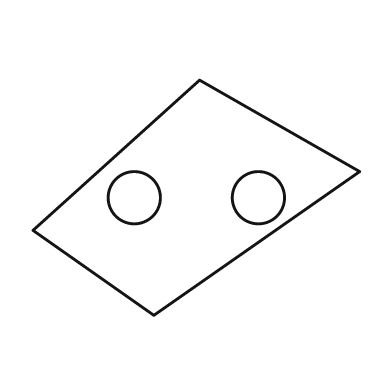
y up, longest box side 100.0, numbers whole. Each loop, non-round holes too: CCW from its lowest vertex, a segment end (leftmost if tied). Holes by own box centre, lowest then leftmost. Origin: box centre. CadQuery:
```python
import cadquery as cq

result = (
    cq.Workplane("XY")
    .moveTo(-13.0, -36.0)
    .lineTo(50.0, 8.0)
    .lineTo(1.0, 36.0)
    .lineTo(-50.0, -10.0)
    .close()
    .moveTo(-19.0, 0.0)
    .circle(8.0)
    .moveTo(19.0, 0.0)
    .circle(8.0)
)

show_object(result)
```